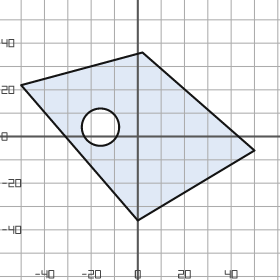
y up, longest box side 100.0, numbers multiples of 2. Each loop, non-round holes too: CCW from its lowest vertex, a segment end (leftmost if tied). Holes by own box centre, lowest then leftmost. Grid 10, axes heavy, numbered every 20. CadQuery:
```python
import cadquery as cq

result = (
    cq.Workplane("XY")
    .moveTo(0.0, -36.0)
    .lineTo(50.0, -6.0)
    .lineTo(2.0, 36.0)
    .lineTo(-50.0, 22.0)
    .close()
    .moveTo(-16.0, 4.0)
    .circle(8.0)
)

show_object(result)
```